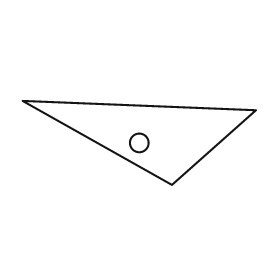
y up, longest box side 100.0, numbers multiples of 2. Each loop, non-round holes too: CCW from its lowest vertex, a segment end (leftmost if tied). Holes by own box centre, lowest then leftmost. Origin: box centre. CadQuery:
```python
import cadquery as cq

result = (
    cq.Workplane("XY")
    .moveTo(14.0, -18.0)
    .lineTo(50.0, 14.0)
    .lineTo(-50.0, 18.0)
    .close()
    .moveTo(0.0, 0.0)
    .circle(4.0)
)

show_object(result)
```